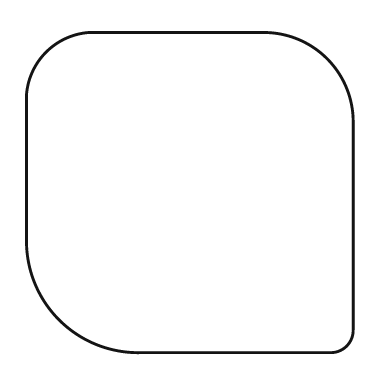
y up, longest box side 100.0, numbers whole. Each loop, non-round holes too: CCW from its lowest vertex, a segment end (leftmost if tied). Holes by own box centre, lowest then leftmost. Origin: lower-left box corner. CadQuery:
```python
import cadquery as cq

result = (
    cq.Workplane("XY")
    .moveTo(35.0, 0.0)
    .lineTo(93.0, 0.0)
    .threePointArc((98.0, 2.0), (100.0, 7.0))
    .lineTo(100.0, 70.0)
    .threePointArc((92.0, 90.0), (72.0, 98.0))
    .lineTo(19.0, 98.0)
    .threePointArc((6.0, 92.0), (0.0, 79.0))
    .lineTo(0.0, 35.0)
    .threePointArc((10.0, 10.0), (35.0, 0.0))
    .close()
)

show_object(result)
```